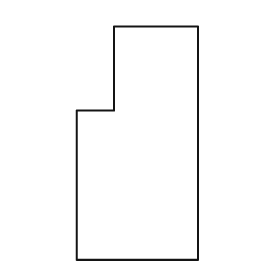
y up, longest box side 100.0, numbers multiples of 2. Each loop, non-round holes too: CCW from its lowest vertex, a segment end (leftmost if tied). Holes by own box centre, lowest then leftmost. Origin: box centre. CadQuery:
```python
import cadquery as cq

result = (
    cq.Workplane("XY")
    .moveTo(-26.0, -50.0)
    .lineTo(26.0, -50.0)
    .lineTo(26.0, 50.0)
    .lineTo(-10.0, 50.0)
    .lineTo(-10.0, 14.0)
    .lineTo(-26.0, 14.0)
    .close()
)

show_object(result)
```